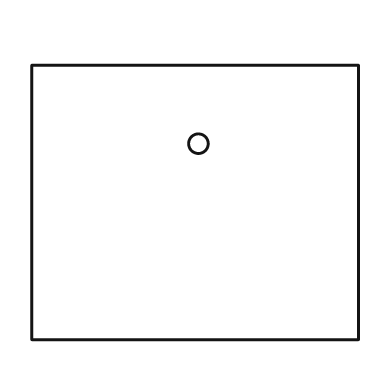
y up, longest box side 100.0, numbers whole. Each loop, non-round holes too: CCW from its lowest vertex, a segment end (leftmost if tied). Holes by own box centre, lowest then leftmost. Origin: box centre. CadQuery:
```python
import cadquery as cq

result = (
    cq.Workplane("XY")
    .moveTo(-50.0, -42.0)
    .lineTo(50.0, -42.0)
    .lineTo(50.0, 42.0)
    .lineTo(-50.0, 42.0)
    .close()
    .moveTo(1.0, 18.0)
    .circle(3.0)
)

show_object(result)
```